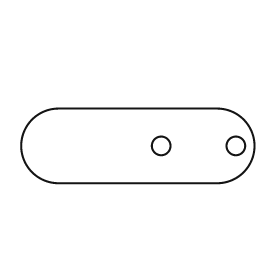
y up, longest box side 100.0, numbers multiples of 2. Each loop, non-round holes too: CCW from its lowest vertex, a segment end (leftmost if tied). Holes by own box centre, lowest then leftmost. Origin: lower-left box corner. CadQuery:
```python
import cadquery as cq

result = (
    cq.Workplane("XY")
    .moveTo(16.0, 0.0)
    .lineTo(84.0, 0.0)
    .threePointArc((100.0, 16.0), (84.0, 32.0))
    .lineTo(16.0, 32.0)
    .threePointArc((0.0, 16.0), (16.0, 0.0))
    .close()
    .moveTo(60.0, 16.0)
    .circle(4.0)
    .moveTo(92.0, 16.0)
    .circle(4.0)
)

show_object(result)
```